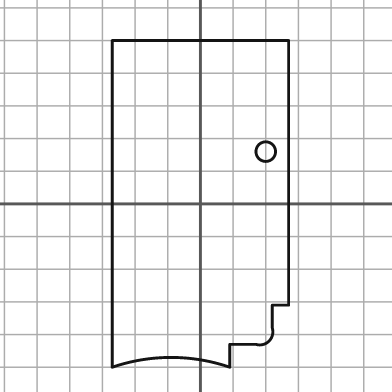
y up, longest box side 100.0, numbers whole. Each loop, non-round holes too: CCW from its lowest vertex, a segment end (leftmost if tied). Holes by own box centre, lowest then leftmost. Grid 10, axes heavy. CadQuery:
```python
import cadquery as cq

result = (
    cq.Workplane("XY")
    .moveTo(-27.0, -50.0)
    .threePointArc((-9.0, -47.0), (9.0, -50.0))
    .lineTo(9.0, -43.0)
    .lineTo(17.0, -43.0)
    .threePointArc((21.0, -42.0), (22.0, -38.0))
    .lineTo(22.0, -31.0)
    .lineTo(27.0, -31.0)
    .lineTo(27.0, 50.0)
    .lineTo(-27.0, 50.0)
    .close()
    .moveTo(20.0, 16.0)
    .circle(3.0)
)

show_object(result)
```